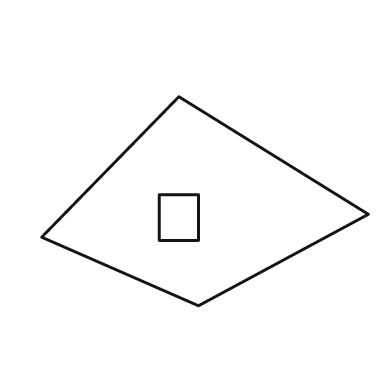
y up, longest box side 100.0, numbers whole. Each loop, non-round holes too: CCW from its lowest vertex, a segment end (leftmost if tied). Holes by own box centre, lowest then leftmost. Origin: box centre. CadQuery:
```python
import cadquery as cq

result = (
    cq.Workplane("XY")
    .moveTo(-2.0, -32.0)
    .lineTo(50.0, -4.0)
    .lineTo(-8.0, 32.0)
    .lineTo(-50.0, -11.0)
    .close()
    .moveTo(-14.0, -12.0)
    .lineTo(-2.0, -12.0)
    .lineTo(-2.0, 2.0)
    .lineTo(-14.0, 2.0)
    .close()
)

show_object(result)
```